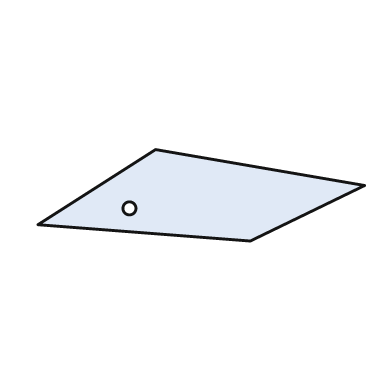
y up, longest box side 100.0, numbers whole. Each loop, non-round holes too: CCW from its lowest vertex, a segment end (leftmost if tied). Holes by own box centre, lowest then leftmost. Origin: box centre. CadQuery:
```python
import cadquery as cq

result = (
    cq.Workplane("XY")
    .moveTo(15.0, -14.0)
    .lineTo(50.0, 3.0)
    .lineTo(-14.0, 14.0)
    .lineTo(-50.0, -9.0)
    .close()
    .moveTo(-22.0, -4.0)
    .circle(2.0)
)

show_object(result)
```